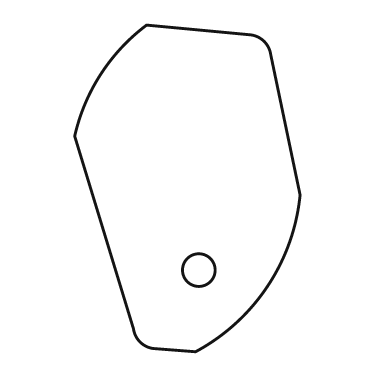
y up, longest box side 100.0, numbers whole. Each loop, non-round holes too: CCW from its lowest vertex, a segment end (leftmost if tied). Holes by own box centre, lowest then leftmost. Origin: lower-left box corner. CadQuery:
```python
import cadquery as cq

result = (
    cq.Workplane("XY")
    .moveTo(37.0, 0.0)
    .threePointArc((59.0, 20.0), (69.0, 48.0))
    .lineTo(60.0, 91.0)
    .threePointArc((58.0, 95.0), (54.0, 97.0))
    .lineTo(22.0, 100.0)
    .threePointArc((8.0, 85.0), (0.0, 66.0))
    .lineTo(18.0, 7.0)
    .threePointArc((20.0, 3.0), (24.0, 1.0))
    .close()
    .moveTo(38.0, 25.0)
    .circle(5.0)
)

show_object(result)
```